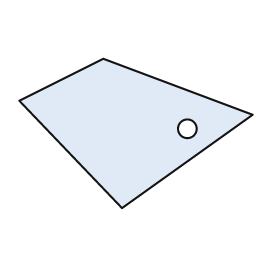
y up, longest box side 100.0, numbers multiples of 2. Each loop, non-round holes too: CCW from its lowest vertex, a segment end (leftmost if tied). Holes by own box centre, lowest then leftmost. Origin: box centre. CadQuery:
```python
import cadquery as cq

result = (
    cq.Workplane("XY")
    .moveTo(-6.0, -32.0)
    .lineTo(50.0, 8.0)
    .lineTo(-14.0, 32.0)
    .lineTo(-50.0, 14.0)
    .close()
    .moveTo(22.0, 2.0)
    .circle(4.0)
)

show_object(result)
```